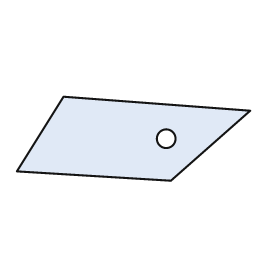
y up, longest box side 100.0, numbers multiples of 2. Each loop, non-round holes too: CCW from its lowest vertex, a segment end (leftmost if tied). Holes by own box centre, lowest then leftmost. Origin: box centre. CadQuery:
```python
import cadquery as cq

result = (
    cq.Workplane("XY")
    .moveTo(16.0, -18.0)
    .lineTo(50.0, 12.0)
    .lineTo(-30.0, 18.0)
    .lineTo(-50.0, -14.0)
    .close()
    .moveTo(14.0, 0.0)
    .circle(4.0)
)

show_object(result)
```